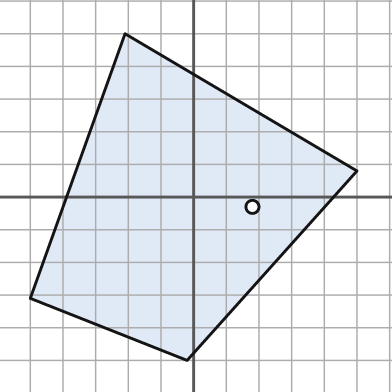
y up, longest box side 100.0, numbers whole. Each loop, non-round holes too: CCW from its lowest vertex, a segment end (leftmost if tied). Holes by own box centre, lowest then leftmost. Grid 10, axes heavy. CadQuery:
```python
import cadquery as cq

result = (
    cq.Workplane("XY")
    .moveTo(-2.0, -50.0)
    .lineTo(50.0, 8.0)
    .lineTo(-21.0, 50.0)
    .lineTo(-50.0, -31.0)
    .close()
    .moveTo(18.0, -3.0)
    .circle(2.0)
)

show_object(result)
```